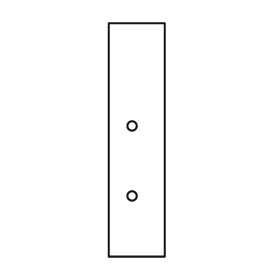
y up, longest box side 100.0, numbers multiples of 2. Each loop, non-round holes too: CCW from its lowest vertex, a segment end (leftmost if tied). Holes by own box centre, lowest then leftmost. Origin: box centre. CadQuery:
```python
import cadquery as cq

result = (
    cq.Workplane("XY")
    .moveTo(-12.0, -50.0)
    .lineTo(12.0, -50.0)
    .lineTo(12.0, 50.0)
    .lineTo(-12.0, 50.0)
    .close()
    .moveTo(-2.0, -24.0)
    .circle(2.0)
    .moveTo(-2.0, 6.0)
    .circle(2.0)
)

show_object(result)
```